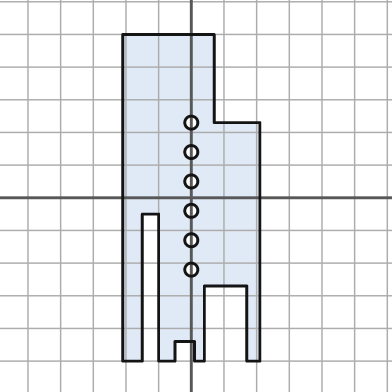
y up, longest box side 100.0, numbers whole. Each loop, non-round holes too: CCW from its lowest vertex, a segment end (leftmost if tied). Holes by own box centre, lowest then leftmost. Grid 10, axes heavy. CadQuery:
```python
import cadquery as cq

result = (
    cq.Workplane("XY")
    .moveTo(-21.0, -50.0)
    .lineTo(-15.0, -50.0)
    .lineTo(-15.0, -5.0)
    .lineTo(-10.0, -5.0)
    .lineTo(-10.0, -50.0)
    .lineTo(-5.0, -50.0)
    .lineTo(-5.0, -44.0)
    .lineTo(1.0, -44.0)
    .lineTo(1.0, -50.0)
    .lineTo(4.0, -50.0)
    .lineTo(4.0, -27.0)
    .lineTo(17.0, -27.0)
    .lineTo(17.0, -50.0)
    .lineTo(21.0, -50.0)
    .lineTo(21.0, 23.0)
    .lineTo(7.0, 23.0)
    .lineTo(7.0, 50.0)
    .lineTo(-21.0, 50.0)
    .close()
    .moveTo(0.0, -22.0)
    .circle(2.0)
    .moveTo(0.0, -13.0)
    .circle(2.0)
    .moveTo(0.0, -4.0)
    .circle(2.0)
    .moveTo(0.0, 5.0)
    .circle(2.0)
    .moveTo(0.0, 14.0)
    .circle(2.0)
    .moveTo(0.0, 23.0)
    .circle(2.0)
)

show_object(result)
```